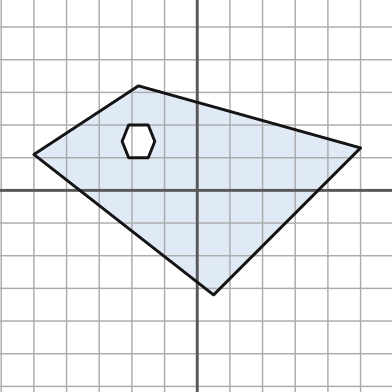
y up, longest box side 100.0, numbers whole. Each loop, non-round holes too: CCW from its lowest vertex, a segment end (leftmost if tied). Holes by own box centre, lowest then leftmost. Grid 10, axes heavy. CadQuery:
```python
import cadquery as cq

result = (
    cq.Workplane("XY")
    .moveTo(5.0, -32.0)
    .lineTo(50.0, 13.0)
    .lineTo(-18.0, 32.0)
    .lineTo(-50.0, 11.0)
    .close()
    .moveTo(-21.0, 10.0)
    .lineTo(-15.0, 10.0)
    .lineTo(-13.0, 15.0)
    .lineTo(-15.0, 20.0)
    .lineTo(-21.0, 20.0)
    .lineTo(-23.0, 15.0)
    .close()
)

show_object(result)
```